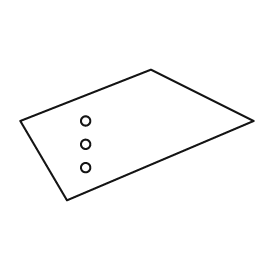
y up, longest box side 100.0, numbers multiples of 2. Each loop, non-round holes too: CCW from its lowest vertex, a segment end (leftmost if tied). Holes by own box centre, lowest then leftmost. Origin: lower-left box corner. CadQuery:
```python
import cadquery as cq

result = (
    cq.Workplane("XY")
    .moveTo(20.0, 0.0)
    .lineTo(100.0, 34.0)
    .lineTo(56.0, 56.0)
    .lineTo(0.0, 34.0)
    .close()
    .moveTo(28.0, 14.0)
    .circle(2.0)
    .moveTo(28.0, 24.0)
    .circle(2.0)
    .moveTo(28.0, 34.0)
    .circle(2.0)
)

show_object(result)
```